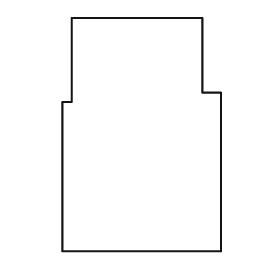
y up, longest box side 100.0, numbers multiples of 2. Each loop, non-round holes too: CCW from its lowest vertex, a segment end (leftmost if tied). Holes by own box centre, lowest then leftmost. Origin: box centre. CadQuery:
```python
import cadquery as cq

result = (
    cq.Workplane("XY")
    .moveTo(-34.0, -50.0)
    .lineTo(34.0, -50.0)
    .lineTo(34.0, 18.0)
    .lineTo(26.0, 18.0)
    .lineTo(26.0, 50.0)
    .lineTo(-30.0, 50.0)
    .lineTo(-30.0, 14.0)
    .lineTo(-34.0, 14.0)
    .close()
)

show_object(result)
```